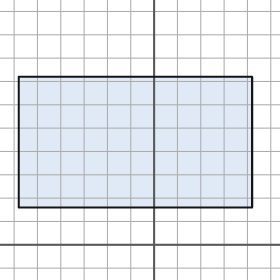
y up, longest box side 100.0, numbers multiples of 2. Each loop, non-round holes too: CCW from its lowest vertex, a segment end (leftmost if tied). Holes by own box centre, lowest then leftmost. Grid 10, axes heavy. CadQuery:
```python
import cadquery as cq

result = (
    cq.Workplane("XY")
    .moveTo(-58.0, 16.0)
    .lineTo(42.0, 16.0)
    .lineTo(42.0, 72.0)
    .lineTo(-58.0, 72.0)
    .close()
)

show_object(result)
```